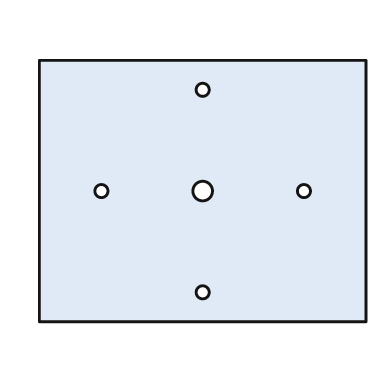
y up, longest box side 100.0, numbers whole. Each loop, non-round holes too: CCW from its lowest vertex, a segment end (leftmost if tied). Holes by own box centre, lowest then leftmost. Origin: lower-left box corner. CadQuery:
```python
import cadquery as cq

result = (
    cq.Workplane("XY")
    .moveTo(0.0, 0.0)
    .lineTo(100.0, 0.0)
    .lineTo(100.0, 80.0)
    .lineTo(0.0, 80.0)
    .close()
    .moveTo(50.0, 9.0)
    .circle(2.0)
    .moveTo(19.0, 40.0)
    .circle(2.0)
    .moveTo(50.0, 40.0)
    .circle(3.0)
    .moveTo(81.0, 40.0)
    .circle(2.0)
    .moveTo(50.0, 71.0)
    .circle(2.0)
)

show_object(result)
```